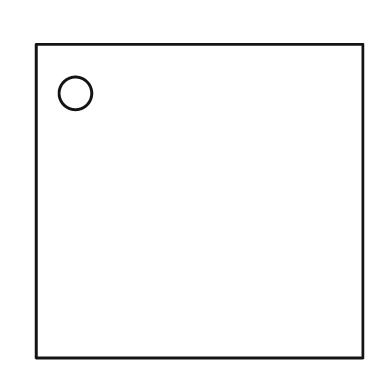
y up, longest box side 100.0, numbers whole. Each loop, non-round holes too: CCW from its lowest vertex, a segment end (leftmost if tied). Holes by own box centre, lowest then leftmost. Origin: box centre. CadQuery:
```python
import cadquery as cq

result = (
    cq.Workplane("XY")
    .moveTo(-50.0, -48.0)
    .lineTo(50.0, -48.0)
    .lineTo(50.0, 48.0)
    .lineTo(-50.0, 48.0)
    .close()
    .moveTo(-38.0, 33.0)
    .circle(5.0)
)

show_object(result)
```